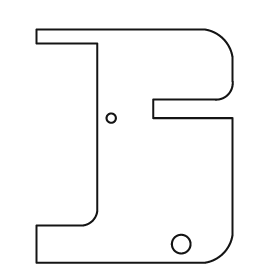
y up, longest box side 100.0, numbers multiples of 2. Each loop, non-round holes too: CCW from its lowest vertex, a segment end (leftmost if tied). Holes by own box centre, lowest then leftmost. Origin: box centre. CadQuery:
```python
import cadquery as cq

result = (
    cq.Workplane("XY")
    .moveTo(-42.0, -50.0)
    .lineTo(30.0, -50.0)
    .threePointArc((38.0, -46.0), (42.0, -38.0))
    .lineTo(42.0, 12.0)
    .lineTo(8.0, 12.0)
    .lineTo(8.0, 20.0)
    .lineTo(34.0, 20.0)
    .threePointArc((40.0, 22.0), (42.0, 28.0))
    .lineTo(42.0, 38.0)
    .threePointArc((38.0, 46.0), (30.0, 50.0))
    .lineTo(-42.0, 50.0)
    .lineTo(-42.0, 44.0)
    .lineTo(-16.0, 44.0)
    .lineTo(-16.0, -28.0)
    .threePointArc((-18.0, -32.0), (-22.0, -34.0))
    .lineTo(-42.0, -34.0)
    .close()
    .moveTo(20.0, -42.0)
    .circle(4.0)
    .moveTo(-10.0, 12.0)
    .circle(2.0)
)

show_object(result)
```